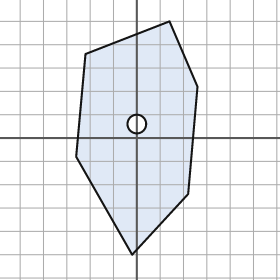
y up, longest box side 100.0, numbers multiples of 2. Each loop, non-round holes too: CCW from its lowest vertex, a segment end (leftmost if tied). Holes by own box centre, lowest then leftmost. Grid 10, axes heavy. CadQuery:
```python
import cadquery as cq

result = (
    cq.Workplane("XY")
    .moveTo(-2.0, -50.0)
    .lineTo(22.0, -24.0)
    .lineTo(26.0, 22.0)
    .lineTo(14.0, 50.0)
    .lineTo(-22.0, 36.0)
    .lineTo(-26.0, -8.0)
    .close()
    .moveTo(0.0, 6.0)
    .circle(4.0)
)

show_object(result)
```